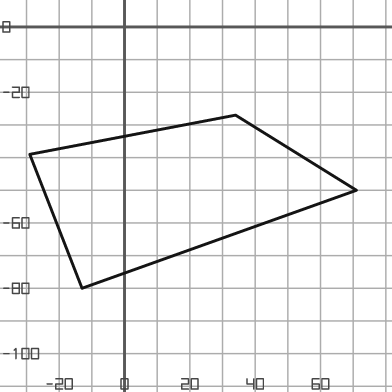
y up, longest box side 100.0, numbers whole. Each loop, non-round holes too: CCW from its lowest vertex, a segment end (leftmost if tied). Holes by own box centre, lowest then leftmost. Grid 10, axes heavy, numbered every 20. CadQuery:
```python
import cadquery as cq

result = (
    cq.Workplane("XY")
    .moveTo(-13.0, -80.0)
    .lineTo(71.0, -50.0)
    .lineTo(34.0, -27.0)
    .lineTo(-29.0, -39.0)
    .close()
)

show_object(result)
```